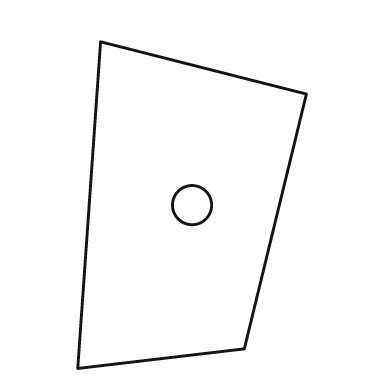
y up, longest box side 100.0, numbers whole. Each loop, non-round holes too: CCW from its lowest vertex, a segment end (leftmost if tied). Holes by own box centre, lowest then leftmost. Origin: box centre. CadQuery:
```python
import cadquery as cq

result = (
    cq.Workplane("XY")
    .moveTo(-35.0, -50.0)
    .lineTo(16.0, -44.0)
    .lineTo(35.0, 34.0)
    .lineTo(-28.0, 50.0)
    .close()
    .moveTo(0.0, 0.0)
    .circle(6.0)
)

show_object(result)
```